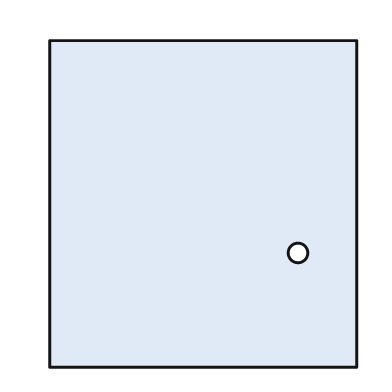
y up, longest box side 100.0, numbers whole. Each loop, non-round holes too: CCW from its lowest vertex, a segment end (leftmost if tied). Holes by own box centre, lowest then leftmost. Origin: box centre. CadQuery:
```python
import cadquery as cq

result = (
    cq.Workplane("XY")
    .moveTo(-47.0, -50.0)
    .lineTo(47.0, -50.0)
    .lineTo(47.0, 50.0)
    .lineTo(-47.0, 50.0)
    .close()
    .moveTo(29.0, -15.0)
    .circle(3.0)
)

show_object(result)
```